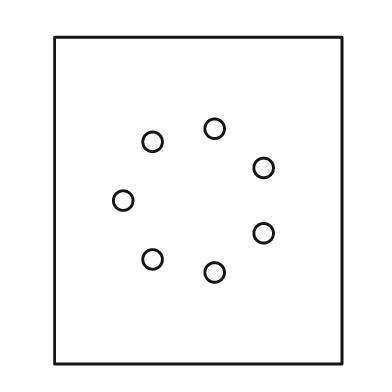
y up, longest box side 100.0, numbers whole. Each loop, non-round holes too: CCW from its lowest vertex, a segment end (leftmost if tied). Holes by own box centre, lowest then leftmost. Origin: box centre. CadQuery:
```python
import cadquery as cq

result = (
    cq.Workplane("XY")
    .moveTo(-44.0, -50.0)
    .lineTo(44.0, -50.0)
    .lineTo(44.0, 50.0)
    .lineTo(-44.0, 50.0)
    .close()
    .moveTo(5.0, -22.0)
    .circle(3.0)
    .moveTo(-14.0, -18.0)
    .circle(3.0)
    .moveTo(20.0, -10.0)
    .circle(3.0)
    .moveTo(-23.0, 0.0)
    .circle(3.0)
    .moveTo(20.0, 10.0)
    .circle(3.0)
    .moveTo(-14.0, 18.0)
    .circle(3.0)
    .moveTo(5.0, 22.0)
    .circle(3.0)
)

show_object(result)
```